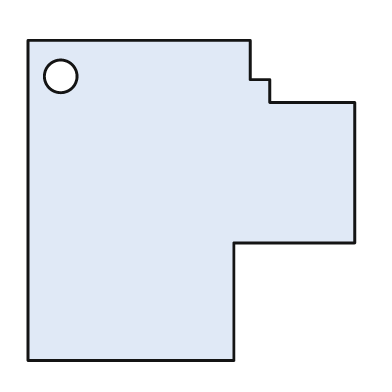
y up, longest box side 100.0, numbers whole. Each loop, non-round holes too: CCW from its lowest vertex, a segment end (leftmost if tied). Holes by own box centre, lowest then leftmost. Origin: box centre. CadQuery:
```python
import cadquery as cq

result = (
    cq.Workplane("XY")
    .moveTo(-50.0, -49.0)
    .lineTo(13.0, -49.0)
    .lineTo(13.0, -13.0)
    .lineTo(50.0, -13.0)
    .lineTo(50.0, 30.0)
    .lineTo(24.0, 30.0)
    .lineTo(24.0, 37.0)
    .lineTo(18.0, 37.0)
    .lineTo(18.0, 49.0)
    .lineTo(-50.0, 49.0)
    .close()
    .moveTo(-40.0, 38.0)
    .circle(5.0)
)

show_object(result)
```